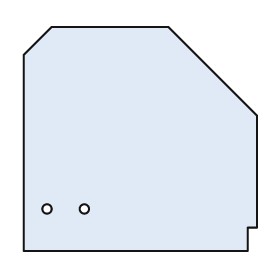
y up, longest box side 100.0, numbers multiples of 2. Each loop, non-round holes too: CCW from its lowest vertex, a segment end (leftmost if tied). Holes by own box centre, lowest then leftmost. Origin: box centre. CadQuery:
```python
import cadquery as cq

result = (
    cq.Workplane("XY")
    .moveTo(-50.0, -48.0)
    .lineTo(46.0, -48.0)
    .lineTo(46.0, -38.0)
    .lineTo(50.0, -38.0)
    .lineTo(50.0, 10.0)
    .lineTo(12.0, 48.0)
    .lineTo(-38.0, 48.0)
    .lineTo(-50.0, 36.0)
    .close()
    .moveTo(-40.0, -30.0)
    .circle(2.0)
    .moveTo(-24.0, -30.0)
    .circle(2.0)
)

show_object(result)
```